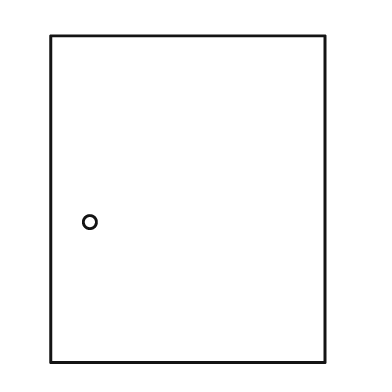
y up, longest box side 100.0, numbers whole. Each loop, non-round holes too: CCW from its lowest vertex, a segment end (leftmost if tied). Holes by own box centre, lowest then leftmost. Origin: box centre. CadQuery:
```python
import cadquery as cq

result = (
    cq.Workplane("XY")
    .moveTo(-42.0, -50.0)
    .lineTo(42.0, -50.0)
    .lineTo(42.0, 50.0)
    .lineTo(-42.0, 50.0)
    .close()
    .moveTo(-30.0, -7.0)
    .circle(2.0)
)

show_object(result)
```